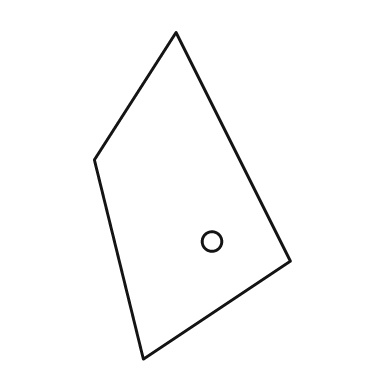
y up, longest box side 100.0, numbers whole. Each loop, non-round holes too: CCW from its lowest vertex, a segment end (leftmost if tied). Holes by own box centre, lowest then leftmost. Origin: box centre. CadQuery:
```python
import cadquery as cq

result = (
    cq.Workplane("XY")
    .moveTo(-15.0, -50.0)
    .lineTo(30.0, -20.0)
    .lineTo(-5.0, 50.0)
    .lineTo(-30.0, 11.0)
    .close()
    .moveTo(6.0, -14.0)
    .circle(3.0)
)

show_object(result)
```